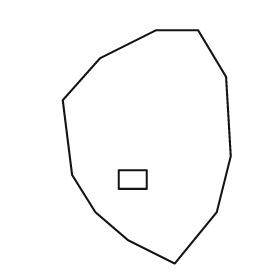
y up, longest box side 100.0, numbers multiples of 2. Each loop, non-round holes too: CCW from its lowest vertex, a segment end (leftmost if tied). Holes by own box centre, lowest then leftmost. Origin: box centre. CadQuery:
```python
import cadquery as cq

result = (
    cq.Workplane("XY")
    .moveTo(12.0, -50.0)
    .lineTo(30.0, -28.0)
    .lineTo(36.0, -4.0)
    .lineTo(34.0, 30.0)
    .lineTo(22.0, 50.0)
    .lineTo(4.0, 50.0)
    .lineTo(-20.0, 38.0)
    .lineTo(-36.0, 20.0)
    .lineTo(-32.0, -12.0)
    .lineTo(-22.0, -28.0)
    .lineTo(-8.0, -40.0)
    .close()
    .moveTo(-12.0, -18.0)
    .lineTo(0.0, -18.0)
    .lineTo(0.0, -10.0)
    .lineTo(-12.0, -10.0)
    .close()
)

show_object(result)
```